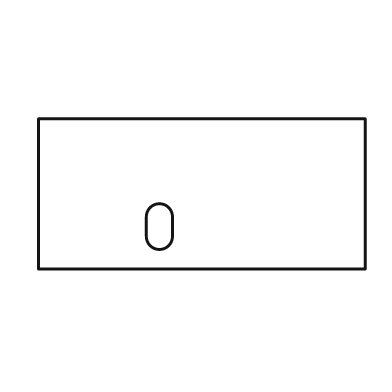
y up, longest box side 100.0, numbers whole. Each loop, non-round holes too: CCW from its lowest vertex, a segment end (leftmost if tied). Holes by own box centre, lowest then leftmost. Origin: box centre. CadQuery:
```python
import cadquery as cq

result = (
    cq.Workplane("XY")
    .moveTo(-50.0, -23.0)
    .lineTo(50.0, -23.0)
    .lineTo(50.0, 23.0)
    .lineTo(-50.0, 23.0)
    .close()
    .moveTo(-17.0, -13.0)
    .threePointArc((-13.0, -17.0), (-9.0, -13.0))
    .lineTo(-9.0, -7.0)
    .threePointArc((-13.0, -3.0), (-17.0, -7.0))
    .close()
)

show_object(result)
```